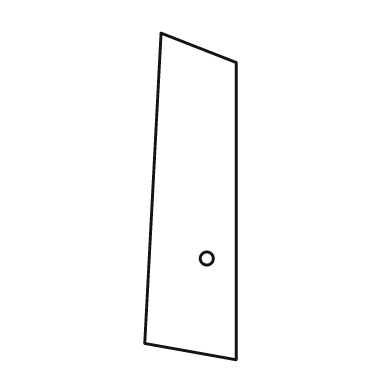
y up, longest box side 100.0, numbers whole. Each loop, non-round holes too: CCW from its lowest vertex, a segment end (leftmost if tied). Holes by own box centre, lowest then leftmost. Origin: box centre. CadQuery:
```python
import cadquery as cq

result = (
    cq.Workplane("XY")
    .moveTo(14.0, -50.0)
    .lineTo(14.0, 41.0)
    .lineTo(-9.0, 50.0)
    .lineTo(-14.0, -45.0)
    .close()
    .moveTo(5.0, -19.0)
    .circle(2.0)
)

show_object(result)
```